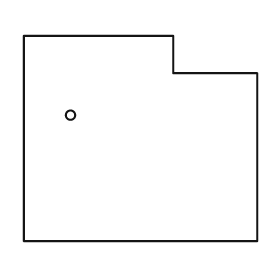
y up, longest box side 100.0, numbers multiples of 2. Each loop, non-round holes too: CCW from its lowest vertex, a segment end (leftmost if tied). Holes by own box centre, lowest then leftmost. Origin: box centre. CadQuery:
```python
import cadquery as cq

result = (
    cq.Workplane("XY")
    .moveTo(-50.0, -44.0)
    .lineTo(50.0, -44.0)
    .lineTo(50.0, 28.0)
    .lineTo(14.0, 28.0)
    .lineTo(14.0, 44.0)
    .lineTo(-50.0, 44.0)
    .close()
    .moveTo(-30.0, 10.0)
    .circle(2.0)
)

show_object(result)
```